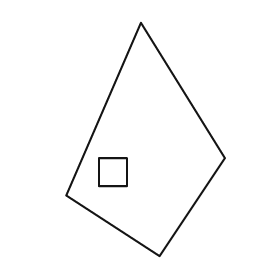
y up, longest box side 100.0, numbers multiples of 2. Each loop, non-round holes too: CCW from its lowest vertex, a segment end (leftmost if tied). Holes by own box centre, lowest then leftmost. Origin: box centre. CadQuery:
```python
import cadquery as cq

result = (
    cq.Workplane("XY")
    .moveTo(6.0, -50.0)
    .lineTo(34.0, -8.0)
    .lineTo(-2.0, 50.0)
    .lineTo(-34.0, -24.0)
    .close()
    .moveTo(-20.0, -20.0)
    .lineTo(-8.0, -20.0)
    .lineTo(-8.0, -8.0)
    .lineTo(-20.0, -8.0)
    .close()
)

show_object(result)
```